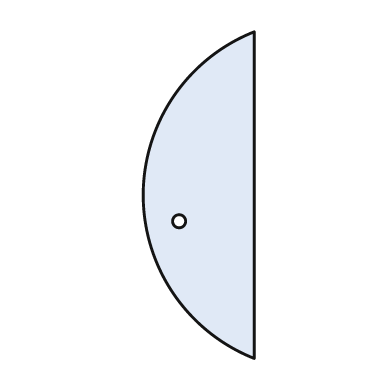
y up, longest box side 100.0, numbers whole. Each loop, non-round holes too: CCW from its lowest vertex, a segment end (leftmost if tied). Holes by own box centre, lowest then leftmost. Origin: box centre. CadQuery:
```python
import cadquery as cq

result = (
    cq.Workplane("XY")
    .moveTo(17.0, -50.0)
    .lineTo(17.0, 50.0)
    .threePointArc((-17.0, 0.0), (17.0, -50.0))
    .close()
    .moveTo(-6.0, -8.0)
    .circle(2.0)
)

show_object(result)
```